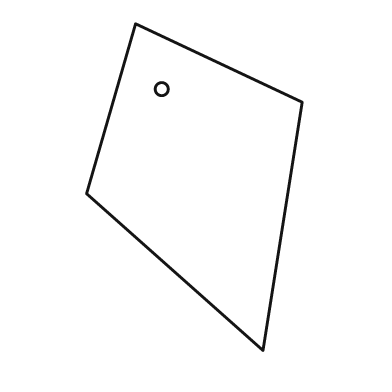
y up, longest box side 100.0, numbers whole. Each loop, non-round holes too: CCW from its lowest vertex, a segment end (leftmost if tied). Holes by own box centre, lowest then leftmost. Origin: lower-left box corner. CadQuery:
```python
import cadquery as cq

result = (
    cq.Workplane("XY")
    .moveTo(54.0, 0.0)
    .lineTo(66.0, 76.0)
    .lineTo(15.0, 100.0)
    .lineTo(0.0, 48.0)
    .close()
    .moveTo(23.0, 80.0)
    .circle(2.0)
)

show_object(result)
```